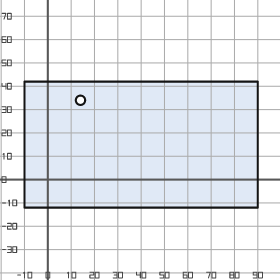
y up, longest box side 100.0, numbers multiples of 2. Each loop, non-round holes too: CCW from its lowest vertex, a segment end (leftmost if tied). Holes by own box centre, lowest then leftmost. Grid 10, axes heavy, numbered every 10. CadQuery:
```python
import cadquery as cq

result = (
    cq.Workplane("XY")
    .moveTo(-10.0, -12.0)
    .lineTo(90.0, -12.0)
    .lineTo(90.0, 42.0)
    .lineTo(-10.0, 42.0)
    .close()
    .moveTo(14.0, 34.0)
    .circle(2.0)
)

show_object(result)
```